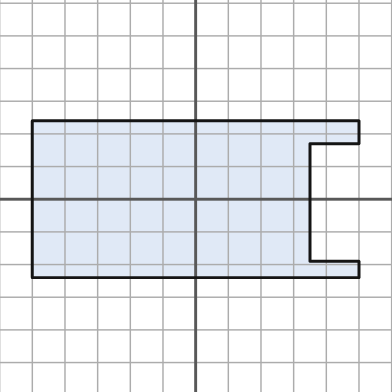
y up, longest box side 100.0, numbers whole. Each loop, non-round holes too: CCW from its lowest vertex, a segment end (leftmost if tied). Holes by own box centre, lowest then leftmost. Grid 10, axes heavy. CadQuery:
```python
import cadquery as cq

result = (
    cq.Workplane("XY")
    .moveTo(-50.0, -24.0)
    .lineTo(50.0, -24.0)
    .lineTo(50.0, -19.0)
    .lineTo(35.0, -19.0)
    .lineTo(35.0, 17.0)
    .lineTo(50.0, 17.0)
    .lineTo(50.0, 24.0)
    .lineTo(-50.0, 24.0)
    .close()
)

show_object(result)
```